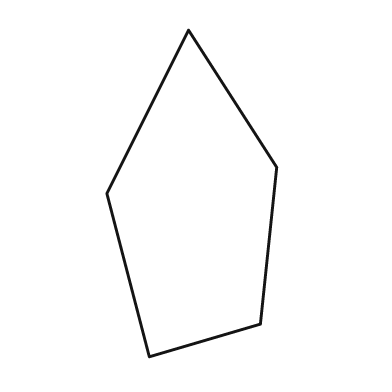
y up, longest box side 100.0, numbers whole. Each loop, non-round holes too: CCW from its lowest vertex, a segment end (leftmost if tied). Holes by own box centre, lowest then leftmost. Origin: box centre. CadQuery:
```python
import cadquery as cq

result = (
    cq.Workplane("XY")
    .moveTo(-13.0, -50.0)
    .lineTo(21.0, -40.0)
    .lineTo(26.0, 8.0)
    .lineTo(-1.0, 50.0)
    .lineTo(-26.0, 0.0)
    .close()
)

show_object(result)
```